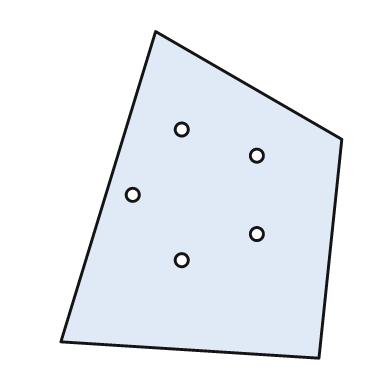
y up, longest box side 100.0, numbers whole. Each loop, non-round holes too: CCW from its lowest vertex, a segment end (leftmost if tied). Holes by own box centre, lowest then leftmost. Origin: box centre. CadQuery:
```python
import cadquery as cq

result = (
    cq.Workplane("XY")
    .moveTo(36.0, -50.0)
    .lineTo(43.0, 17.0)
    .lineTo(-14.0, 50.0)
    .lineTo(-43.0, -45.0)
    .close()
    .moveTo(-6.0, -20.0)
    .circle(2.0)
    .moveTo(17.0, -12.0)
    .circle(2.0)
    .moveTo(-21.0, 0.0)
    .circle(2.0)
    .moveTo(17.0, 12.0)
    .circle(2.0)
    .moveTo(-6.0, 20.0)
    .circle(2.0)
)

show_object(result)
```